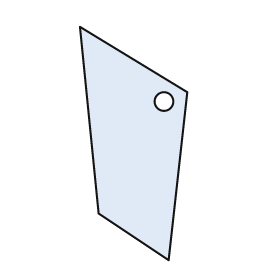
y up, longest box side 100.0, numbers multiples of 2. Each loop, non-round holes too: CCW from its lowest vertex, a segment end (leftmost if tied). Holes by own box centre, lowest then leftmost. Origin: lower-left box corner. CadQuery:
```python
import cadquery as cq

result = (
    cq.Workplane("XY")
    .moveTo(38.0, 0.0)
    .lineTo(46.0, 72.0)
    .lineTo(0.0, 100.0)
    .lineTo(8.0, 20.0)
    .close()
    .moveTo(36.0, 68.0)
    .circle(4.0)
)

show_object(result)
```